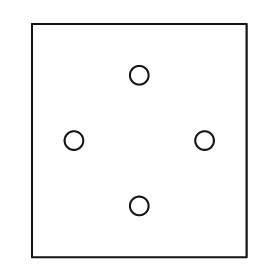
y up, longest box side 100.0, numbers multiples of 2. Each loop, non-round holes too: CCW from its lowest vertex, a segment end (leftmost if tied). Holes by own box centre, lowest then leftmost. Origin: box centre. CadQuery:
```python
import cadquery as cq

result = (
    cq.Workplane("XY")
    .moveTo(-46.0, -50.0)
    .lineTo(46.0, -50.0)
    .lineTo(46.0, 50.0)
    .lineTo(-46.0, 50.0)
    .close()
    .moveTo(0.0, -28.0)
    .circle(4.0)
    .moveTo(-28.0, 0.0)
    .circle(4.0)
    .moveTo(28.0, 0.0)
    .circle(4.0)
    .moveTo(0.0, 28.0)
    .circle(4.0)
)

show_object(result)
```